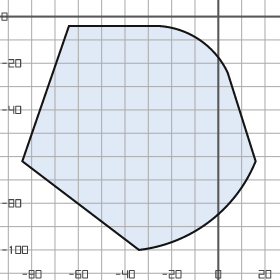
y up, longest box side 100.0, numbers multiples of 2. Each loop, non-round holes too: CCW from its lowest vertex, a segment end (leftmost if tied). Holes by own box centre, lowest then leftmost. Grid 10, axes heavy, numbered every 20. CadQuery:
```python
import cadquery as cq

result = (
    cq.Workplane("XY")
    .moveTo(-34.0, -100.0)
    .threePointArc((-4.0, -88.0), (16.0, -62.0))
    .lineTo(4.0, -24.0)
    .threePointArc((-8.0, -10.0), (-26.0, -4.0))
    .lineTo(-64.0, -4.0)
    .lineTo(-84.0, -62.0)
    .close()
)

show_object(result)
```